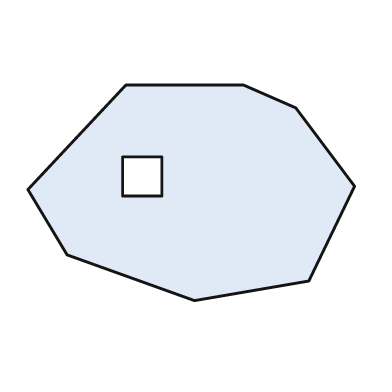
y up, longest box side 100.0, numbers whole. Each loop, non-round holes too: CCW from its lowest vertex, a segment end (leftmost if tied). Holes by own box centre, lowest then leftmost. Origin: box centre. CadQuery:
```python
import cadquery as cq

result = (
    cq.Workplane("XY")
    .moveTo(1.0, -33.0)
    .lineTo(36.0, -27.0)
    .lineTo(50.0, 2.0)
    .lineTo(32.0, 26.0)
    .lineTo(16.0, 33.0)
    .lineTo(-20.0, 33.0)
    .lineTo(-50.0, 1.0)
    .lineTo(-38.0, -19.0)
    .close()
    .moveTo(-21.0, -1.0)
    .lineTo(-9.0, -1.0)
    .lineTo(-9.0, 11.0)
    .lineTo(-21.0, 11.0)
    .close()
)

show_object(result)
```